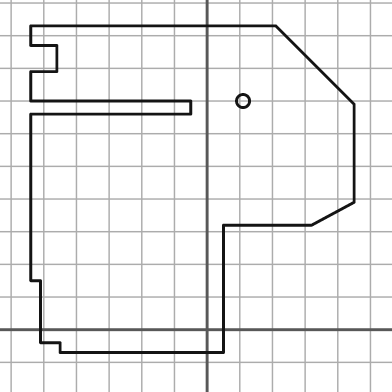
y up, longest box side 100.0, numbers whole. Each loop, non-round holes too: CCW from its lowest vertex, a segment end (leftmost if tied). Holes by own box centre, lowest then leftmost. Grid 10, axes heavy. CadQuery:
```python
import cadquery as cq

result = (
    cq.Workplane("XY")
    .moveTo(-45.0, -7.0)
    .lineTo(5.0, -7.0)
    .lineTo(5.0, 32.0)
    .lineTo(32.0, 32.0)
    .lineTo(45.0, 39.0)
    .lineTo(45.0, 69.0)
    .lineTo(21.0, 93.0)
    .lineTo(-54.0, 93.0)
    .lineTo(-54.0, 87.0)
    .lineTo(-46.0, 87.0)
    .lineTo(-46.0, 79.0)
    .lineTo(-54.0, 79.0)
    .lineTo(-54.0, 70.0)
    .lineTo(-5.0, 70.0)
    .lineTo(-5.0, 66.0)
    .lineTo(-54.0, 66.0)
    .lineTo(-54.0, 15.0)
    .lineTo(-51.0, 15.0)
    .lineTo(-51.0, -4.0)
    .lineTo(-45.0, -4.0)
    .close()
    .moveTo(11.0, 70.0)
    .circle(2.0)
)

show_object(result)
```